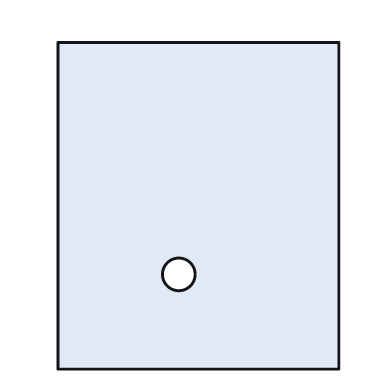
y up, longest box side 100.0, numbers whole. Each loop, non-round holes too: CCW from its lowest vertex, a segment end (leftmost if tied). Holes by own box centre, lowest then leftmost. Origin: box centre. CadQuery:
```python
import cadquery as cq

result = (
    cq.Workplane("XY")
    .moveTo(-43.0, -50.0)
    .lineTo(43.0, -50.0)
    .lineTo(43.0, 50.0)
    .lineTo(-43.0, 50.0)
    .close()
    .moveTo(-6.0, -21.0)
    .circle(5.0)
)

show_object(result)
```